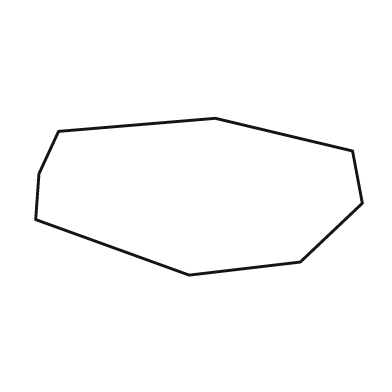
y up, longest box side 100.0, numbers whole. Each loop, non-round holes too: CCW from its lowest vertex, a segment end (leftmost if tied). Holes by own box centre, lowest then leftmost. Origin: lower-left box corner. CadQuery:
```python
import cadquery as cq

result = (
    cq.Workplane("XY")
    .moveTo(47.0, 0.0)
    .lineTo(81.0, 4.0)
    .lineTo(100.0, 22.0)
    .lineTo(97.0, 38.0)
    .lineTo(55.0, 48.0)
    .lineTo(7.0, 44.0)
    .lineTo(1.0, 31.0)
    .lineTo(0.0, 17.0)
    .close()
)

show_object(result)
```